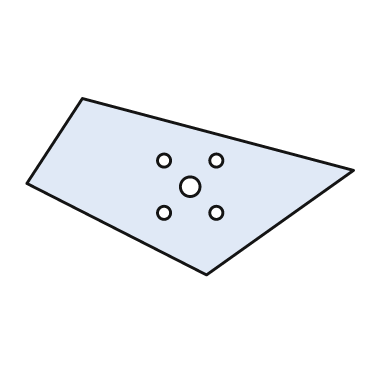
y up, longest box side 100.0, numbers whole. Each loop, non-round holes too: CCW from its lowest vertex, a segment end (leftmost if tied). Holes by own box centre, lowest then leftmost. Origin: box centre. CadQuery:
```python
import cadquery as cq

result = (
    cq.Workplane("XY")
    .moveTo(5.0, -27.0)
    .lineTo(50.0, 5.0)
    .lineTo(-33.0, 27.0)
    .lineTo(-50.0, 1.0)
    .close()
    .moveTo(-8.0, -8.0)
    .circle(2.0)
    .moveTo(8.0, -8.0)
    .circle(2.0)
    .moveTo(0.0, 0.0)
    .circle(3.0)
    .moveTo(-8.0, 8.0)
    .circle(2.0)
    .moveTo(8.0, 8.0)
    .circle(2.0)
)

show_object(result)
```